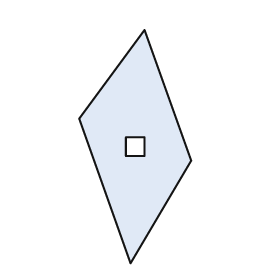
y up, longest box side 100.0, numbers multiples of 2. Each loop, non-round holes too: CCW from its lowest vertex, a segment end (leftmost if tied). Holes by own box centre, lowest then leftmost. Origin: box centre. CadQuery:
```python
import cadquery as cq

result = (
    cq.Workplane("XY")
    .moveTo(-2.0, -50.0)
    .lineTo(24.0, -6.0)
    .lineTo(4.0, 50.0)
    .lineTo(-24.0, 12.0)
    .close()
    .moveTo(-4.0, -4.0)
    .lineTo(4.0, -4.0)
    .lineTo(4.0, 4.0)
    .lineTo(-4.0, 4.0)
    .close()
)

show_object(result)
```